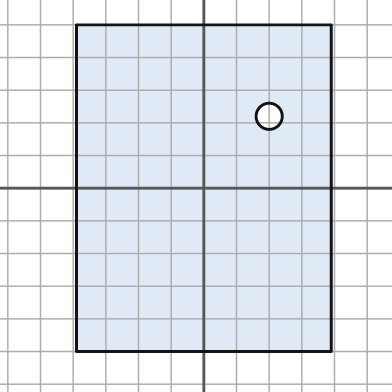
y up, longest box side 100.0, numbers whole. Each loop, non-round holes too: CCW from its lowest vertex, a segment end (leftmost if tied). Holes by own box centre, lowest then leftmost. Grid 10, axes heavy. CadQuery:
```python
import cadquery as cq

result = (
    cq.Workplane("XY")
    .moveTo(-39.0, -50.0)
    .lineTo(39.0, -50.0)
    .lineTo(39.0, 50.0)
    .lineTo(-39.0, 50.0)
    .close()
    .moveTo(20.0, 22.0)
    .circle(4.0)
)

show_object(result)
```